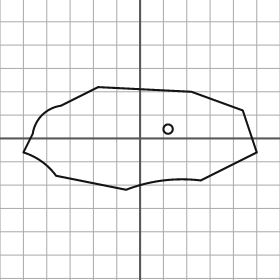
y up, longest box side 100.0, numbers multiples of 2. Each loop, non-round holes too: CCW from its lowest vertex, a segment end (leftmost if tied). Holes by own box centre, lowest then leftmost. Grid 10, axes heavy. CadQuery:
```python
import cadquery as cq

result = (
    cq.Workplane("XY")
    .moveTo(-6.0, -22.0)
    .threePointArc((10.0, -18.0), (26.0, -18.0))
    .lineTo(50.0, -6.0)
    .lineTo(44.0, 12.0)
    .lineTo(22.0, 20.0)
    .lineTo(-18.0, 22.0)
    .lineTo(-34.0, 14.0)
    .threePointArc((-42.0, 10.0), (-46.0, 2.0))
    .lineTo(-50.0, -6.0)
    .threePointArc((-42.0, -10.0), (-36.0, -16.0))
    .close()
    .moveTo(12.0, 4.0)
    .circle(2.0)
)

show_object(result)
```